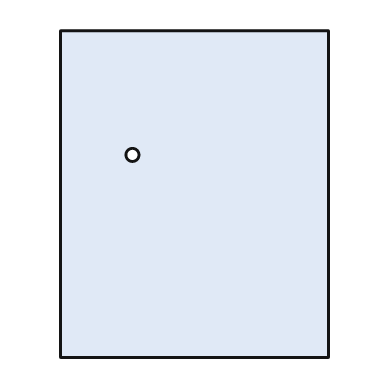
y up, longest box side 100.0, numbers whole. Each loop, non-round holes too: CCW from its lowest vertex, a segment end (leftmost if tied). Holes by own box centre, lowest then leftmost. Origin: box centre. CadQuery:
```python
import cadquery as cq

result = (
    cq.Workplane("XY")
    .moveTo(-41.0, -50.0)
    .lineTo(41.0, -50.0)
    .lineTo(41.0, 50.0)
    .lineTo(-41.0, 50.0)
    .close()
    .moveTo(-19.0, 12.0)
    .circle(2.0)
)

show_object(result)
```